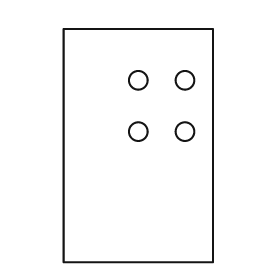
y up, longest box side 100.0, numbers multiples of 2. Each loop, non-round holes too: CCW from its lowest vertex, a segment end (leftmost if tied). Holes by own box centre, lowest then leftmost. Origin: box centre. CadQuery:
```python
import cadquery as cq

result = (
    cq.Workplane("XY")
    .moveTo(-32.0, -50.0)
    .lineTo(32.0, -50.0)
    .lineTo(32.0, 50.0)
    .lineTo(-32.0, 50.0)
    .close()
    .moveTo(0.0, 6.0)
    .circle(4.0)
    .moveTo(20.0, 6.0)
    .circle(4.0)
    .moveTo(0.0, 28.0)
    .circle(4.0)
    .moveTo(20.0, 28.0)
    .circle(4.0)
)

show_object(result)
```